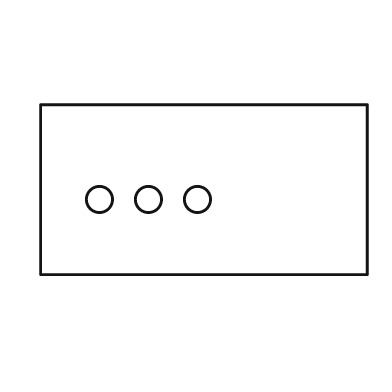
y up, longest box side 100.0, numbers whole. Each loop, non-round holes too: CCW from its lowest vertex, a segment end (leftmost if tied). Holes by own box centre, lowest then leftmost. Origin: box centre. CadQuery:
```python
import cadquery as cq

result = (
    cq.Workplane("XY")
    .moveTo(-50.0, -26.0)
    .lineTo(50.0, -26.0)
    .lineTo(50.0, 26.0)
    .lineTo(-50.0, 26.0)
    .close()
    .moveTo(-32.0, -3.0)
    .circle(4.0)
    .moveTo(-17.0, -3.0)
    .circle(4.0)
    .moveTo(-2.0, -3.0)
    .circle(4.0)
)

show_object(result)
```